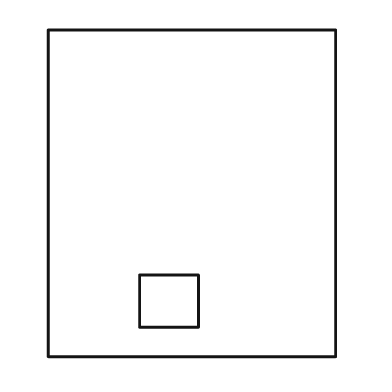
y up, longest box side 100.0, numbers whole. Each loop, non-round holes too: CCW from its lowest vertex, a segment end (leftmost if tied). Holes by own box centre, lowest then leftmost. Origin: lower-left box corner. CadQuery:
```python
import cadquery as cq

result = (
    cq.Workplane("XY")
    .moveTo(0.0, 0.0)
    .lineTo(88.0, 0.0)
    .lineTo(88.0, 100.0)
    .lineTo(0.0, 100.0)
    .close()
    .moveTo(28.0, 9.0)
    .lineTo(46.0, 9.0)
    .lineTo(46.0, 25.0)
    .lineTo(28.0, 25.0)
    .close()
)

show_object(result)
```